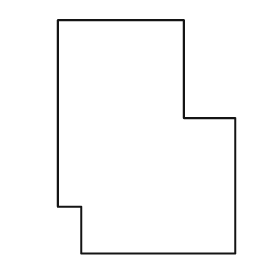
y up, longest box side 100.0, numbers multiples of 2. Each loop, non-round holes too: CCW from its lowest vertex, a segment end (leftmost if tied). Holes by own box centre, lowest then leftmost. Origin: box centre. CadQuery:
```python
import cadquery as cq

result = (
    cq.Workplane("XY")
    .moveTo(-28.0, -50.0)
    .lineTo(38.0, -50.0)
    .lineTo(38.0, 8.0)
    .lineTo(16.0, 8.0)
    .lineTo(16.0, 50.0)
    .lineTo(-38.0, 50.0)
    .lineTo(-38.0, -30.0)
    .lineTo(-28.0, -30.0)
    .close()
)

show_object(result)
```